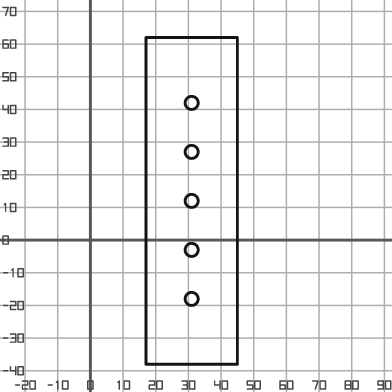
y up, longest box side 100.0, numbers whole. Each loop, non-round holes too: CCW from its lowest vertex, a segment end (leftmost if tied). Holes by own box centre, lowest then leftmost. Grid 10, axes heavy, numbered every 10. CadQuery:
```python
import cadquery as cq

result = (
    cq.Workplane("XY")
    .moveTo(17.0, -38.0)
    .lineTo(45.0, -38.0)
    .lineTo(45.0, 62.0)
    .lineTo(17.0, 62.0)
    .close()
    .moveTo(31.0, -18.0)
    .circle(2.0)
    .moveTo(31.0, -3.0)
    .circle(2.0)
    .moveTo(31.0, 12.0)
    .circle(2.0)
    .moveTo(31.0, 27.0)
    .circle(2.0)
    .moveTo(31.0, 42.0)
    .circle(2.0)
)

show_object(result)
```